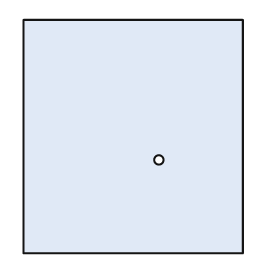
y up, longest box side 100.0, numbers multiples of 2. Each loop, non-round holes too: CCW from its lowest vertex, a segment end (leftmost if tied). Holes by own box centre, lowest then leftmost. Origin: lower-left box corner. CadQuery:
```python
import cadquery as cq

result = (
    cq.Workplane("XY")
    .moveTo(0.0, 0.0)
    .lineTo(94.0, 0.0)
    .lineTo(94.0, 100.0)
    .lineTo(0.0, 100.0)
    .close()
    .moveTo(58.0, 40.0)
    .circle(2.0)
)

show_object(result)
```